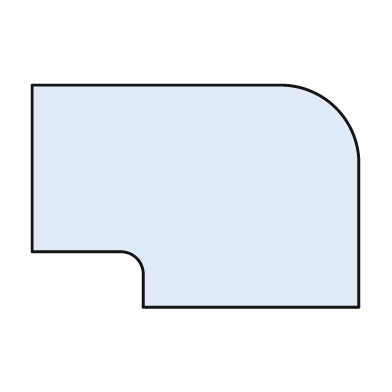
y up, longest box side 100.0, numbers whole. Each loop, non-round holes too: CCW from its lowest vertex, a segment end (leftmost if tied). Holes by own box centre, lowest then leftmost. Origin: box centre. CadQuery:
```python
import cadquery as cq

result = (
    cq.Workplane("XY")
    .moveTo(-16.0, -34.0)
    .lineTo(50.0, -34.0)
    .lineTo(50.0, 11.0)
    .threePointArc((43.0, 27.0), (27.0, 34.0))
    .lineTo(-50.0, 34.0)
    .lineTo(-50.0, -17.0)
    .lineTo(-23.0, -17.0)
    .threePointArc((-18.0, -19.0), (-16.0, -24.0))
    .close()
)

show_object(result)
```